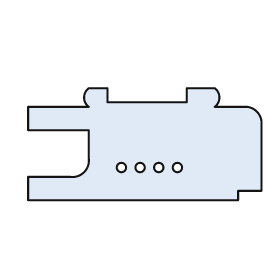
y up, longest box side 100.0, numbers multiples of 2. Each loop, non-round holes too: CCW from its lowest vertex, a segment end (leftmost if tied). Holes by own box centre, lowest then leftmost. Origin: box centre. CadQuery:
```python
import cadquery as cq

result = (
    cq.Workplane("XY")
    .moveTo(-50.0, -24.0)
    .lineTo(40.0, -24.0)
    .lineTo(40.0, -20.0)
    .lineTo(50.0, -20.0)
    .lineTo(50.0, 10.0)
    .threePointArc((48.0, 14.0), (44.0, 16.0))
    .lineTo(30.0, 16.0)
    .threePointArc((32.0, 20.0), (30.0, 24.0))
    .lineTo(18.0, 24.0)
    .lineTo(18.0, 18.0)
    .lineTo(-16.0, 18.0)
    .lineTo(-16.0, 24.0)
    .lineTo(-24.0, 24.0)
    .threePointArc((-26.0, 20.0), (-24.0, 16.0))
    .lineTo(-50.0, 16.0)
    .lineTo(-50.0, 6.0)
    .lineTo(-24.0, 6.0)
    .lineTo(-24.0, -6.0)
    .threePointArc((-26.0, -12.0), (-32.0, -14.0))
    .lineTo(-50.0, -14.0)
    .close()
    .moveTo(-10.0, -10.0)
    .circle(2.0)
    .moveTo(-2.0, -10.0)
    .circle(2.0)
    .moveTo(6.0, -10.0)
    .circle(2.0)
    .moveTo(14.0, -10.0)
    .circle(2.0)
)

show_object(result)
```